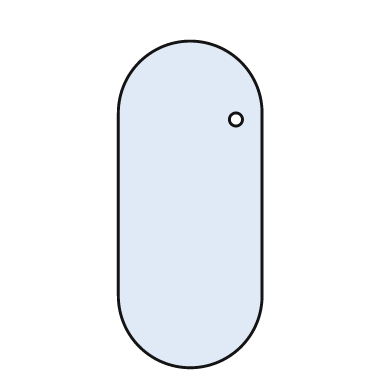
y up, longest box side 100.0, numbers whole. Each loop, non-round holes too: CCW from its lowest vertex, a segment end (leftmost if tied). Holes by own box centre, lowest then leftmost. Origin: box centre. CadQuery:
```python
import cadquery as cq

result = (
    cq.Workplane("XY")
    .moveTo(-22.0, -28.0)
    .threePointArc((0.0, -50.0), (22.0, -28.0))
    .lineTo(22.0, 28.0)
    .threePointArc((0.0, 50.0), (-22.0, 28.0))
    .close()
    .moveTo(14.0, 26.0)
    .circle(2.0)
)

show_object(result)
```